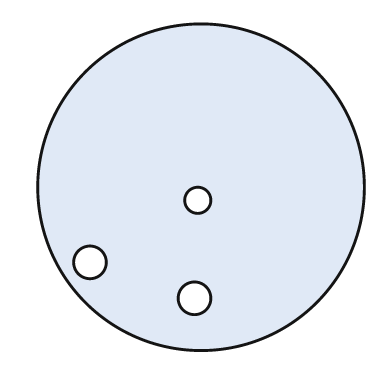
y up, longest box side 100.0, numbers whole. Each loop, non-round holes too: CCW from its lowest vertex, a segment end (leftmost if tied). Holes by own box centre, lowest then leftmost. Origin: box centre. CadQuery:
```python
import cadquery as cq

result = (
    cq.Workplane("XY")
    .moveTo(0.0, 0.0)
    .circle(50.0)
    .moveTo(-2.0, -34.0)
    .circle(5.0)
    .moveTo(-34.0, -23.0)
    .circle(5.0)
    .moveTo(-1.0, -4.0)
    .circle(4.0)
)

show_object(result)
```